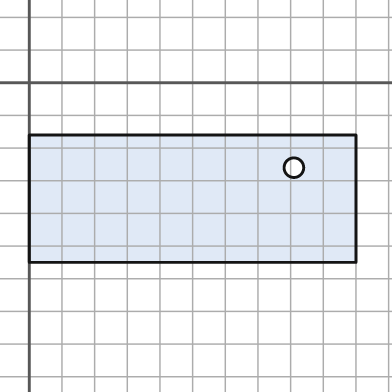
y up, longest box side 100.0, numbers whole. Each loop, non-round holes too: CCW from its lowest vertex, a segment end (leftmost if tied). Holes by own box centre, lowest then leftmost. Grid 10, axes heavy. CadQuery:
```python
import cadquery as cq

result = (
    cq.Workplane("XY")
    .moveTo(0.0, -55.0)
    .lineTo(100.0, -55.0)
    .lineTo(100.0, -16.0)
    .lineTo(0.0, -16.0)
    .close()
    .moveTo(81.0, -26.0)
    .circle(3.0)
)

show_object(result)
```